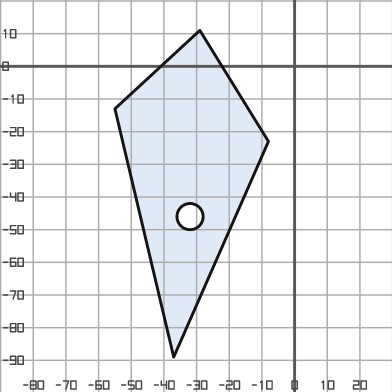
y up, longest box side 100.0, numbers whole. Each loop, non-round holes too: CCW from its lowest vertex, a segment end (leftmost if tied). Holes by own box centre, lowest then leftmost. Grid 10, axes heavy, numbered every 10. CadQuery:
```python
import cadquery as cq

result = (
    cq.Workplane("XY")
    .moveTo(-37.0, -89.0)
    .lineTo(-8.0, -23.0)
    .lineTo(-29.0, 11.0)
    .lineTo(-55.0, -13.0)
    .close()
    .moveTo(-32.0, -46.0)
    .circle(4.0)
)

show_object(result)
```